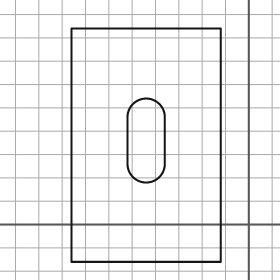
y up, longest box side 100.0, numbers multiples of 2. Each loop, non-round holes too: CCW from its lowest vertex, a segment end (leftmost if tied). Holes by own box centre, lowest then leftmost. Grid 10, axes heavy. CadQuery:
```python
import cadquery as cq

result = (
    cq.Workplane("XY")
    .moveTo(-76.0, -16.0)
    .lineTo(-12.0, -16.0)
    .lineTo(-12.0, 84.0)
    .lineTo(-76.0, 84.0)
    .close()
    .moveTo(-52.0, 26.0)
    .threePointArc((-44.0, 18.0), (-36.0, 26.0))
    .lineTo(-36.0, 46.0)
    .threePointArc((-44.0, 54.0), (-52.0, 46.0))
    .close()
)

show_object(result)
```